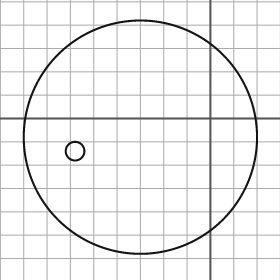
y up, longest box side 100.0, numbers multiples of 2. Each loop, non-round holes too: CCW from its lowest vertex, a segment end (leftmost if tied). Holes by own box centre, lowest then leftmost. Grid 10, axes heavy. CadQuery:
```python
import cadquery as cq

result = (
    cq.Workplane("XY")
    .moveTo(-30.0, -8.0)
    .circle(50.0)
    .moveTo(-58.0, -14.0)
    .circle(4.0)
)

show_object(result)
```